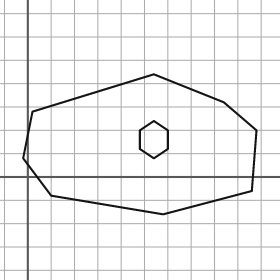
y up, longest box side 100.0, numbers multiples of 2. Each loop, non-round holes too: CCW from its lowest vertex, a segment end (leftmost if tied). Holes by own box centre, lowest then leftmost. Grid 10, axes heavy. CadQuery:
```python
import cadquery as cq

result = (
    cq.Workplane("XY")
    .moveTo(58.0, -16.0)
    .lineTo(96.0, -6.0)
    .lineTo(98.0, 20.0)
    .lineTo(84.0, 32.0)
    .lineTo(54.0, 44.0)
    .lineTo(2.0, 28.0)
    .lineTo(-2.0, 8.0)
    .lineTo(10.0, -8.0)
    .close()
    .moveTo(54.0, 8.0)
    .lineTo(60.0, 12.0)
    .lineTo(60.0, 20.0)
    .lineTo(54.0, 24.0)
    .lineTo(48.0, 20.0)
    .lineTo(48.0, 12.0)
    .close()
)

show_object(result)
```